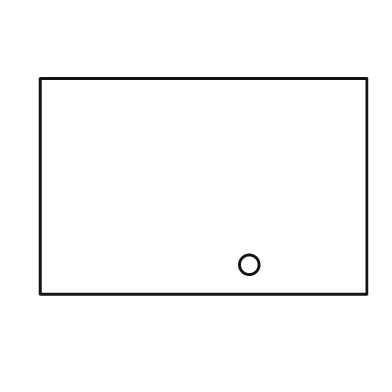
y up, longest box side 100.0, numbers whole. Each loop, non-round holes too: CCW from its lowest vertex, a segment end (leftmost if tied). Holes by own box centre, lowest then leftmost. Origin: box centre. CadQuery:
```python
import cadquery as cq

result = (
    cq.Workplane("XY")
    .moveTo(-50.0, -33.0)
    .lineTo(50.0, -33.0)
    .lineTo(50.0, 33.0)
    .lineTo(-50.0, 33.0)
    .close()
    .moveTo(14.0, -24.0)
    .circle(3.0)
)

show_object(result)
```